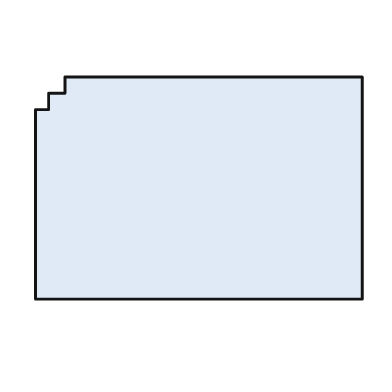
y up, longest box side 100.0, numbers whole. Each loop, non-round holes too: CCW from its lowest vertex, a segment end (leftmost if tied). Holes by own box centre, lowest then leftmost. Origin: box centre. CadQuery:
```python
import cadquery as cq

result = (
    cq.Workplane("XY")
    .moveTo(-50.0, -34.0)
    .lineTo(50.0, -34.0)
    .lineTo(50.0, 34.0)
    .lineTo(-41.0, 34.0)
    .lineTo(-41.0, 29.0)
    .lineTo(-46.0, 29.0)
    .lineTo(-46.0, 24.0)
    .lineTo(-50.0, 24.0)
    .close()
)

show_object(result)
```